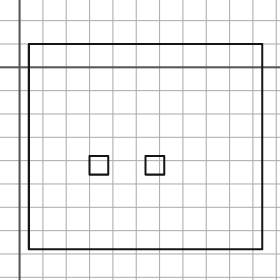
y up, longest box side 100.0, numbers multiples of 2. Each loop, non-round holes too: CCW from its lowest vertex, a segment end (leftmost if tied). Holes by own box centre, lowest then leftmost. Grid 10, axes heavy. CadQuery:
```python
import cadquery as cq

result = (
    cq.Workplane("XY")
    .moveTo(4.0, -78.0)
    .lineTo(104.0, -78.0)
    .lineTo(104.0, 10.0)
    .lineTo(4.0, 10.0)
    .close()
    .moveTo(30.0, -46.0)
    .lineTo(38.0, -46.0)
    .lineTo(38.0, -38.0)
    .lineTo(30.0, -38.0)
    .close()
    .moveTo(54.0, -46.0)
    .lineTo(62.0, -46.0)
    .lineTo(62.0, -38.0)
    .lineTo(54.0, -38.0)
    .close()
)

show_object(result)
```